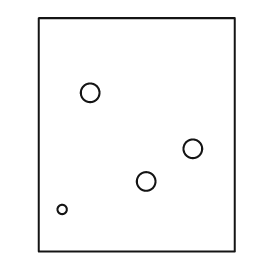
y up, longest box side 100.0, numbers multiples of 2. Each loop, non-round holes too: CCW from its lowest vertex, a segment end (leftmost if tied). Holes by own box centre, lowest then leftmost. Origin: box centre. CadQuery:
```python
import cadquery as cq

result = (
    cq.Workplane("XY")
    .moveTo(-42.0, -50.0)
    .lineTo(42.0, -50.0)
    .lineTo(42.0, 50.0)
    .lineTo(-42.0, 50.0)
    .close()
    .moveTo(-32.0, -32.0)
    .circle(2.0)
    .moveTo(4.0, -20.0)
    .circle(4.0)
    .moveTo(24.0, -6.0)
    .circle(4.0)
    .moveTo(-20.0, 18.0)
    .circle(4.0)
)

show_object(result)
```